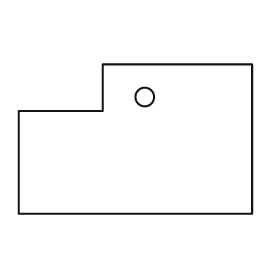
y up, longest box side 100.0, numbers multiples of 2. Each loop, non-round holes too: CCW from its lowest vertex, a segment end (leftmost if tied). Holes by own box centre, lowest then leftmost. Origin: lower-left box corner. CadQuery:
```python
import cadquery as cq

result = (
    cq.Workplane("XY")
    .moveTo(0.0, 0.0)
    .lineTo(100.0, 0.0)
    .lineTo(100.0, 64.0)
    .lineTo(36.0, 64.0)
    .lineTo(36.0, 44.0)
    .lineTo(0.0, 44.0)
    .close()
    .moveTo(54.0, 50.0)
    .circle(4.0)
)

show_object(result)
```